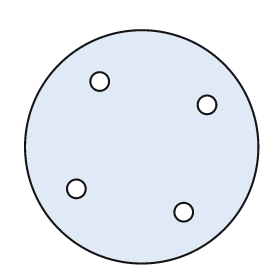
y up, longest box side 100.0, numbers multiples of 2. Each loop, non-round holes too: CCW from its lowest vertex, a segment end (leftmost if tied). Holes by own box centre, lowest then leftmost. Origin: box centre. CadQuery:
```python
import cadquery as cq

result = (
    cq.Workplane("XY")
    .moveTo(0.0, 0.0)
    .circle(50.0)
    .moveTo(18.0, -28.0)
    .circle(4.0)
    .moveTo(-28.0, -18.0)
    .circle(4.0)
    .moveTo(28.0, 18.0)
    .circle(4.0)
    .moveTo(-18.0, 28.0)
    .circle(4.0)
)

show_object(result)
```